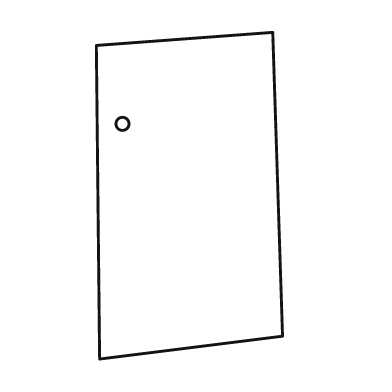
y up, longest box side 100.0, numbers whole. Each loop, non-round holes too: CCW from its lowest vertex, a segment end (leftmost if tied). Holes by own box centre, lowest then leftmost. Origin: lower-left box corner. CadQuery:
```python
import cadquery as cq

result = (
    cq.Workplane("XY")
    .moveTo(1.0, 0.0)
    .lineTo(57.0, 7.0)
    .lineTo(54.0, 100.0)
    .lineTo(0.0, 96.0)
    .close()
    .moveTo(8.0, 72.0)
    .circle(2.0)
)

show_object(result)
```